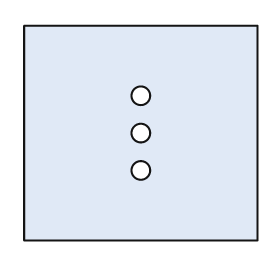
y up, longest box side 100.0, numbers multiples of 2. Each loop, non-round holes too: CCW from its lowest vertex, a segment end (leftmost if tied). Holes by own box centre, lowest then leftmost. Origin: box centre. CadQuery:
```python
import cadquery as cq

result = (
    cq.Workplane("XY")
    .moveTo(-50.0, -46.0)
    .lineTo(50.0, -46.0)
    .lineTo(50.0, 46.0)
    .lineTo(-50.0, 46.0)
    .close()
    .moveTo(0.0, -16.0)
    .circle(4.0)
    .moveTo(0.0, 0.0)
    .circle(4.0)
    .moveTo(0.0, 16.0)
    .circle(4.0)
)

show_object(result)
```